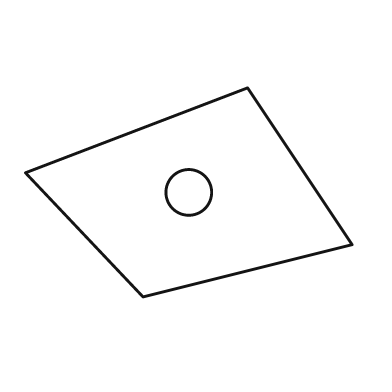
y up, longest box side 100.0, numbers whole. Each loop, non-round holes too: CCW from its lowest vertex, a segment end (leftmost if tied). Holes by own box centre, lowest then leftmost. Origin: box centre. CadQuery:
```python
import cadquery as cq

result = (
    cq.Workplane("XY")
    .moveTo(-14.0, -32.0)
    .lineTo(50.0, -16.0)
    .lineTo(18.0, 32.0)
    .lineTo(-50.0, 6.0)
    .close()
    .moveTo(0.0, 0.0)
    .circle(7.0)
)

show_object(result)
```